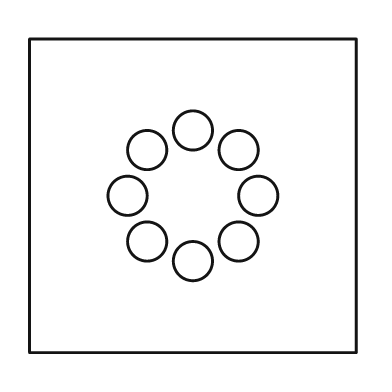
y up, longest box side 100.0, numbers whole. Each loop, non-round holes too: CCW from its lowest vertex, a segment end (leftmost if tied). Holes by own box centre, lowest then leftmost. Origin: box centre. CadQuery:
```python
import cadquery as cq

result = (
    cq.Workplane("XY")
    .moveTo(-50.0, -48.0)
    .lineTo(50.0, -48.0)
    .lineTo(50.0, 48.0)
    .lineTo(-50.0, 48.0)
    .close()
    .moveTo(0.0, -20.0)
    .circle(6.0)
    .moveTo(-14.0, -14.0)
    .circle(6.0)
    .moveTo(14.0, -14.0)
    .circle(6.0)
    .moveTo(-20.0, 0.0)
    .circle(6.0)
    .moveTo(20.0, 0.0)
    .circle(6.0)
    .moveTo(-14.0, 14.0)
    .circle(6.0)
    .moveTo(14.0, 14.0)
    .circle(6.0)
    .moveTo(0.0, 20.0)
    .circle(6.0)
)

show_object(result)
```